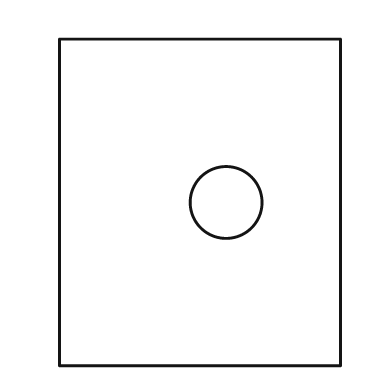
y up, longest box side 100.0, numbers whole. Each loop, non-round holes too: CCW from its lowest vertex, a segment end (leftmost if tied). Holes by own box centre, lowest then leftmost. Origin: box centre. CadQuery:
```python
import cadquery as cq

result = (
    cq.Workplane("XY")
    .moveTo(-43.0, -50.0)
    .lineTo(43.0, -50.0)
    .lineTo(43.0, 50.0)
    .lineTo(-43.0, 50.0)
    .close()
    .moveTo(8.0, 0.0)
    .circle(11.0)
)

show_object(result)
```